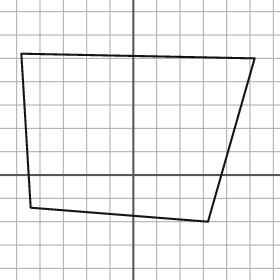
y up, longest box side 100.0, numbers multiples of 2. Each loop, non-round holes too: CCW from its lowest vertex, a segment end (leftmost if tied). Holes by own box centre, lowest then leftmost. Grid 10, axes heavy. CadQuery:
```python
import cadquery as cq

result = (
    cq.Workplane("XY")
    .moveTo(32.0, -20.0)
    .lineTo(52.0, 50.0)
    .lineTo(-48.0, 52.0)
    .lineTo(-44.0, -14.0)
    .close()
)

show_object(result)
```